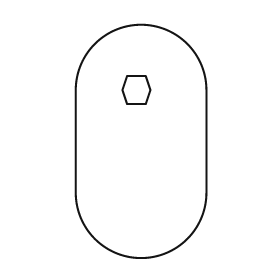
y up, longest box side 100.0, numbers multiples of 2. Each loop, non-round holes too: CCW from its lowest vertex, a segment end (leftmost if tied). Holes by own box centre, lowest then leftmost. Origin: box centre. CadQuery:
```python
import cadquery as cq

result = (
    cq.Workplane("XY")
    .moveTo(-28.0, -22.0)
    .threePointArc((0.0, -50.0), (28.0, -22.0))
    .lineTo(28.0, 22.0)
    .threePointArc((0.0, 50.0), (-28.0, 22.0))
    .close()
    .moveTo(-6.0, 16.0)
    .lineTo(2.0, 16.0)
    .lineTo(4.0, 22.0)
    .lineTo(2.0, 28.0)
    .lineTo(-6.0, 28.0)
    .lineTo(-8.0, 22.0)
    .close()
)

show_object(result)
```